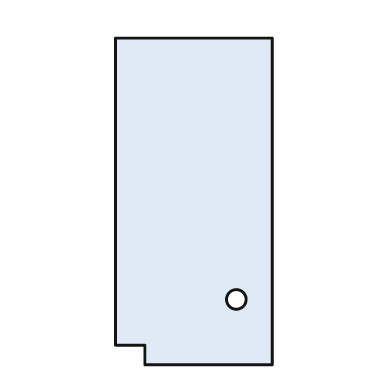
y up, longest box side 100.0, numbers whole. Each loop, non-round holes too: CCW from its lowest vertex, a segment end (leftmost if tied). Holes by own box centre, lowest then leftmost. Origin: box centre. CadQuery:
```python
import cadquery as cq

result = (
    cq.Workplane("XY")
    .moveTo(-15.0, -50.0)
    .lineTo(24.0, -50.0)
    .lineTo(24.0, 50.0)
    .lineTo(-24.0, 50.0)
    .lineTo(-24.0, -44.0)
    .lineTo(-15.0, -44.0)
    .close()
    .moveTo(13.0, -30.0)
    .circle(3.0)
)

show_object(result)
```